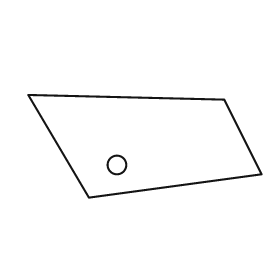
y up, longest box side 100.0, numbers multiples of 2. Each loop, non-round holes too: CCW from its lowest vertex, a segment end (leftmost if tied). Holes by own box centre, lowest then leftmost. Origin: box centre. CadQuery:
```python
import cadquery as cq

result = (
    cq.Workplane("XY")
    .moveTo(-24.0, -22.0)
    .lineTo(50.0, -12.0)
    .lineTo(34.0, 20.0)
    .lineTo(-50.0, 22.0)
    .close()
    .moveTo(-12.0, -8.0)
    .circle(4.0)
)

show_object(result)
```